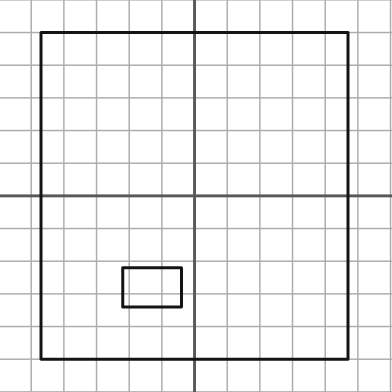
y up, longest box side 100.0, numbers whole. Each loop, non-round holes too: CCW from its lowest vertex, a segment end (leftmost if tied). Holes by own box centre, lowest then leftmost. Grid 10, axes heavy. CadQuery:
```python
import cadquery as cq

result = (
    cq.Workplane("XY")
    .moveTo(-47.0, -50.0)
    .lineTo(47.0, -50.0)
    .lineTo(47.0, 50.0)
    .lineTo(-47.0, 50.0)
    .close()
    .moveTo(-22.0, -34.0)
    .lineTo(-4.0, -34.0)
    .lineTo(-4.0, -22.0)
    .lineTo(-22.0, -22.0)
    .close()
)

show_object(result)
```